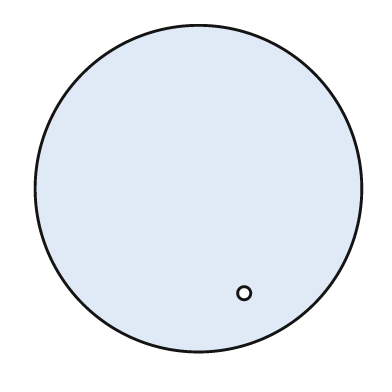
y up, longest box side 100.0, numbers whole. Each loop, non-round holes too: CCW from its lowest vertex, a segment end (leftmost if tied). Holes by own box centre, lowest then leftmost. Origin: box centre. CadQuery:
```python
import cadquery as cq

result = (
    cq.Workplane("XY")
    .moveTo(0.0, 0.0)
    .circle(50.0)
    .moveTo(14.0, -32.0)
    .circle(2.0)
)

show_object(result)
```